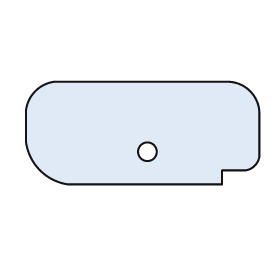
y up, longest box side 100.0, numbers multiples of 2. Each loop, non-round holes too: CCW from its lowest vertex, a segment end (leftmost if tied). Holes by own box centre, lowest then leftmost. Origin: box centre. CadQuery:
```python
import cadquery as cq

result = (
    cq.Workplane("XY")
    .moveTo(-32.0, -22.0)
    .lineTo(34.0, -22.0)
    .lineTo(34.0, -16.0)
    .lineTo(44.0, -16.0)
    .threePointArc((48.0, -14.0), (50.0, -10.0))
    .lineTo(50.0, 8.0)
    .threePointArc((46.0, 18.0), (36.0, 22.0))
    .lineTo(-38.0, 22.0)
    .threePointArc((-46.0, 18.0), (-50.0, 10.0))
    .lineTo(-50.0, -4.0)
    .threePointArc((-44.0, -16.0), (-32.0, -22.0))
    .close()
    .moveTo(2.0, -8.0)
    .circle(4.0)
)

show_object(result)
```